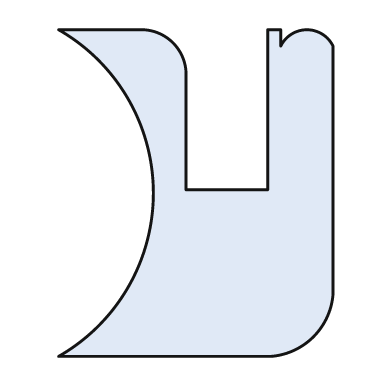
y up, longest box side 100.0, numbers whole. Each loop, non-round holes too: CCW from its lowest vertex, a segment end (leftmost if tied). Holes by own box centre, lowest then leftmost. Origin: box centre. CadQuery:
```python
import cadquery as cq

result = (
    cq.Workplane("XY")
    .moveTo(-42.0, -50.0)
    .lineTo(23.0, -50.0)
    .threePointArc((36.0, -44.0), (42.0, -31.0))
    .lineTo(42.0, 45.0)
    .threePointArc((34.0, 50.0), (26.0, 45.0))
    .lineTo(26.0, 50.0)
    .lineTo(22.0, 50.0)
    .lineTo(22.0, 1.0)
    .lineTo(-3.0, 1.0)
    .lineTo(-3.0, 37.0)
    .threePointArc((-7.0, 46.0), (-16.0, 50.0))
    .lineTo(-42.0, 50.0)
    .threePointArc((-13.0, 0.0), (-42.0, -50.0))
    .close()
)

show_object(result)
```